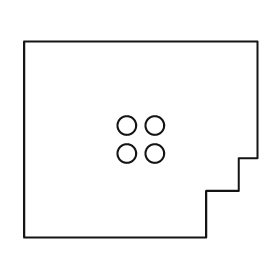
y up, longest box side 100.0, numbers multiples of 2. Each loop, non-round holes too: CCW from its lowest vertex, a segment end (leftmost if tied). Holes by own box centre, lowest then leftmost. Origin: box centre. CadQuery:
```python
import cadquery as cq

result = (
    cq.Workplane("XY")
    .moveTo(-50.0, -42.0)
    .lineTo(28.0, -42.0)
    .lineTo(28.0, -22.0)
    .lineTo(42.0, -22.0)
    .lineTo(42.0, -8.0)
    .lineTo(50.0, -8.0)
    .lineTo(50.0, 42.0)
    .lineTo(-50.0, 42.0)
    .close()
    .moveTo(-6.0, -6.0)
    .circle(4.0)
    .moveTo(6.0, -6.0)
    .circle(4.0)
    .moveTo(-6.0, 6.0)
    .circle(4.0)
    .moveTo(6.0, 6.0)
    .circle(4.0)
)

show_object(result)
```